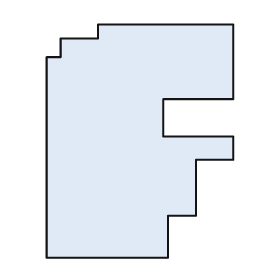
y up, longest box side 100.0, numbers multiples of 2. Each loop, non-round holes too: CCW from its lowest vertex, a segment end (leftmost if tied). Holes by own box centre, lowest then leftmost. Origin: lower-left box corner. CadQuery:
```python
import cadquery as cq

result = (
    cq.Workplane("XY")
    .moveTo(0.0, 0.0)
    .lineTo(52.0, 0.0)
    .lineTo(52.0, 18.0)
    .lineTo(64.0, 18.0)
    .lineTo(64.0, 42.0)
    .lineTo(80.0, 42.0)
    .lineTo(80.0, 52.0)
    .lineTo(50.0, 52.0)
    .lineTo(50.0, 68.0)
    .lineTo(80.0, 68.0)
    .lineTo(80.0, 100.0)
    .lineTo(22.0, 100.0)
    .lineTo(22.0, 94.0)
    .lineTo(6.0, 94.0)
    .lineTo(6.0, 86.0)
    .lineTo(0.0, 86.0)
    .close()
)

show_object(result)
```